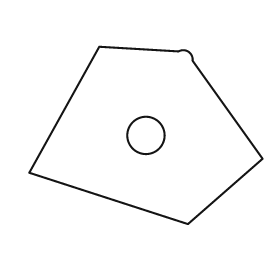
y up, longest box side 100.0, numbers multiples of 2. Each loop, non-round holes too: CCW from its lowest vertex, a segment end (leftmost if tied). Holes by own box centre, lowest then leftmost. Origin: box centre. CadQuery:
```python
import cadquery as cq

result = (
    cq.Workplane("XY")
    .moveTo(18.0, -38.0)
    .lineTo(50.0, -10.0)
    .lineTo(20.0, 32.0)
    .threePointArc((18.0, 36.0), (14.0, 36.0))
    .lineTo(-20.0, 38.0)
    .lineTo(-50.0, -16.0)
    .close()
    .moveTo(0.0, 0.0)
    .circle(8.0)
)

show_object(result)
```